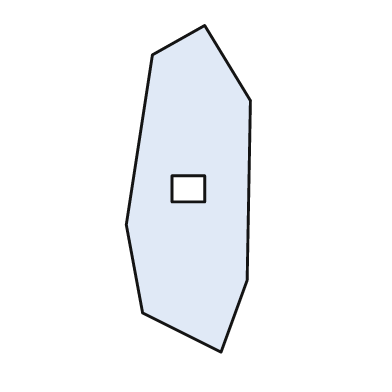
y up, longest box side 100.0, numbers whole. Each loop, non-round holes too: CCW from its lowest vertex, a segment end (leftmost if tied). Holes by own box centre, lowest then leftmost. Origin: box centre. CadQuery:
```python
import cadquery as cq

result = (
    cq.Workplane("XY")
    .moveTo(10.0, -50.0)
    .lineTo(18.0, -28.0)
    .lineTo(19.0, 27.0)
    .lineTo(5.0, 50.0)
    .lineTo(-11.0, 41.0)
    .lineTo(-19.0, -11.0)
    .lineTo(-14.0, -38.0)
    .close()
    .moveTo(-5.0, -4.0)
    .lineTo(5.0, -4.0)
    .lineTo(5.0, 4.0)
    .lineTo(-5.0, 4.0)
    .close()
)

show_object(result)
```